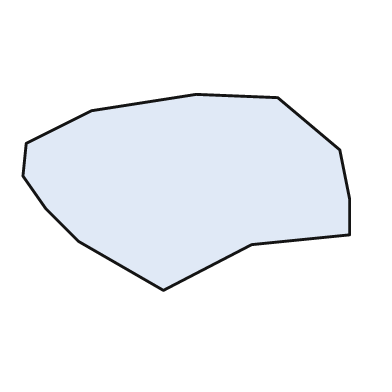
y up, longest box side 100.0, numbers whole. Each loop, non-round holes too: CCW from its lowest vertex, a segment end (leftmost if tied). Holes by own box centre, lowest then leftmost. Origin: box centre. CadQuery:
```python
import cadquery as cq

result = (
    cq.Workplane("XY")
    .moveTo(-7.0, -30.0)
    .lineTo(20.0, -16.0)
    .lineTo(50.0, -13.0)
    .lineTo(50.0, -2.0)
    .lineTo(47.0, 13.0)
    .lineTo(28.0, 29.0)
    .lineTo(3.0, 30.0)
    .lineTo(-29.0, 25.0)
    .lineTo(-49.0, 15.0)
    .lineTo(-50.0, 5.0)
    .lineTo(-43.0, -5.0)
    .lineTo(-33.0, -15.0)
    .close()
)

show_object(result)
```